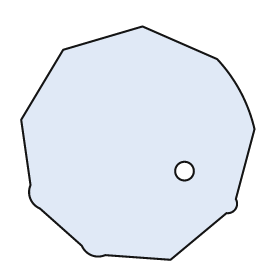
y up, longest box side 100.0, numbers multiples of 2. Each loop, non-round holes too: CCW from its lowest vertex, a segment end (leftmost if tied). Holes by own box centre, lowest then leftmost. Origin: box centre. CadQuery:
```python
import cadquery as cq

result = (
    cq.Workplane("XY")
    .moveTo(14.0, -50.0)
    .lineTo(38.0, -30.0)
    .threePointArc((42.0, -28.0), (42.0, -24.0))
    .lineTo(50.0, 6.0)
    .threePointArc((44.0, 22.0), (34.0, 36.0))
    .lineTo(2.0, 50.0)
    .lineTo(-32.0, 40.0)
    .lineTo(-50.0, 10.0)
    .lineTo(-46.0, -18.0)
    .threePointArc((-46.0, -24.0), (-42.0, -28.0))
    .lineTo(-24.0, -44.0)
    .threePointArc((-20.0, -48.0), (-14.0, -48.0))
    .close()
    .moveTo(20.0, -12.0)
    .circle(4.0)
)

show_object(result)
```